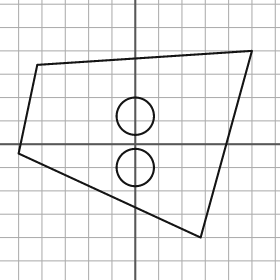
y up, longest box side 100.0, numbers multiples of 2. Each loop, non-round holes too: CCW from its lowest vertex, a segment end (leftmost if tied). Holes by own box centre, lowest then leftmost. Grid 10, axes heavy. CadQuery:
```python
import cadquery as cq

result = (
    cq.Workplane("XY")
    .moveTo(28.0, -40.0)
    .lineTo(50.0, 40.0)
    .lineTo(-42.0, 34.0)
    .lineTo(-50.0, -4.0)
    .close()
    .moveTo(0.0, -10.0)
    .circle(8.0)
    .moveTo(0.0, 12.0)
    .circle(8.0)
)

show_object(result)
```